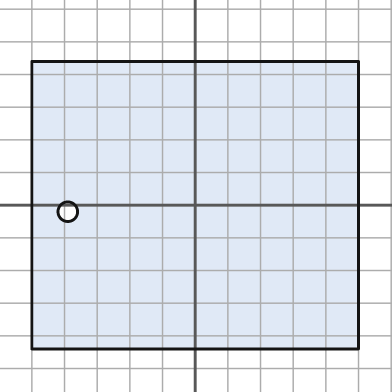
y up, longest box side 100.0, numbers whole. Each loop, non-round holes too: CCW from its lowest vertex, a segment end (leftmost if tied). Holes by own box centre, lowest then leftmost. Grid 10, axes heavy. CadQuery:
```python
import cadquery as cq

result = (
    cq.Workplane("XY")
    .moveTo(-50.0, -44.0)
    .lineTo(50.0, -44.0)
    .lineTo(50.0, 44.0)
    .lineTo(-50.0, 44.0)
    .close()
    .moveTo(-39.0, -2.0)
    .circle(3.0)
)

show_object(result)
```